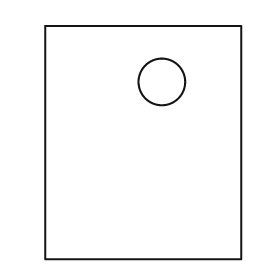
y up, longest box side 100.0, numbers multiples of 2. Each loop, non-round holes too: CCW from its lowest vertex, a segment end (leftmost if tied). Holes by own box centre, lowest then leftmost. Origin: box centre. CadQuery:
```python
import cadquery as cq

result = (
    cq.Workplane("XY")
    .moveTo(-42.0, -50.0)
    .lineTo(42.0, -50.0)
    .lineTo(42.0, 50.0)
    .lineTo(-42.0, 50.0)
    .close()
    .moveTo(8.0, 26.0)
    .circle(10.0)
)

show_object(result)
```